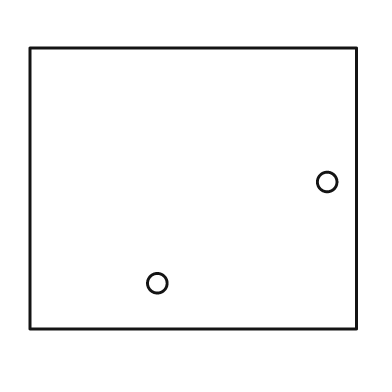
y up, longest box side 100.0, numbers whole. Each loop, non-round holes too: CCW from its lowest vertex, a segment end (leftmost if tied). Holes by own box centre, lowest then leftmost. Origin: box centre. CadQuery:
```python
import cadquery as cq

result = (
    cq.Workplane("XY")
    .moveTo(-50.0, -43.0)
    .lineTo(50.0, -43.0)
    .lineTo(50.0, 43.0)
    .lineTo(-50.0, 43.0)
    .close()
    .moveTo(-11.0, -29.0)
    .circle(3.0)
    .moveTo(41.0, 2.0)
    .circle(3.0)
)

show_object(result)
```